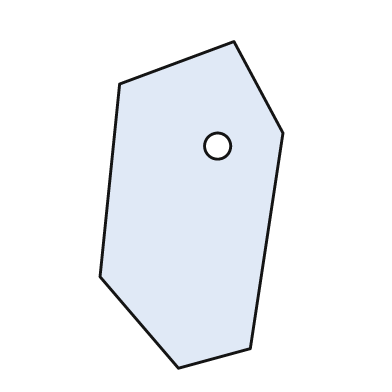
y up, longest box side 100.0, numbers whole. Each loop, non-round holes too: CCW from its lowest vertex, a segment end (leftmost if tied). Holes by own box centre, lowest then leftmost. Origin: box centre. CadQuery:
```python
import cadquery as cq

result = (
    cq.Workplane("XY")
    .moveTo(-4.0, -50.0)
    .lineTo(18.0, -44.0)
    .lineTo(28.0, 22.0)
    .lineTo(13.0, 50.0)
    .lineTo(-22.0, 37.0)
    .lineTo(-28.0, -22.0)
    .close()
    .moveTo(8.0, 18.0)
    .circle(4.0)
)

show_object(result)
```